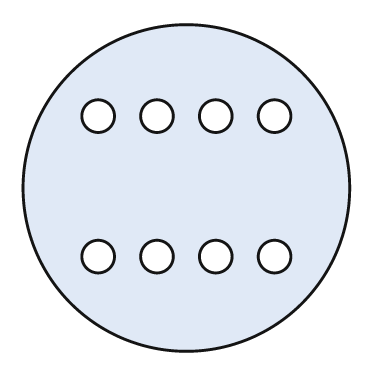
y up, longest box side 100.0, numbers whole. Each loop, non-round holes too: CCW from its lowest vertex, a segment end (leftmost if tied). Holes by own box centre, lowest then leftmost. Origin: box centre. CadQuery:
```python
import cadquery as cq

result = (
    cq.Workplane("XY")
    .moveTo(0.0, 0.0)
    .circle(50.0)
    .moveTo(-27.0, -21.0)
    .circle(5.0)
    .moveTo(-9.0, -21.0)
    .circle(5.0)
    .moveTo(9.0, -21.0)
    .circle(5.0)
    .moveTo(27.0, -21.0)
    .circle(5.0)
    .moveTo(-27.0, 22.0)
    .circle(5.0)
    .moveTo(-9.0, 22.0)
    .circle(5.0)
    .moveTo(9.0, 22.0)
    .circle(5.0)
    .moveTo(27.0, 22.0)
    .circle(5.0)
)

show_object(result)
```